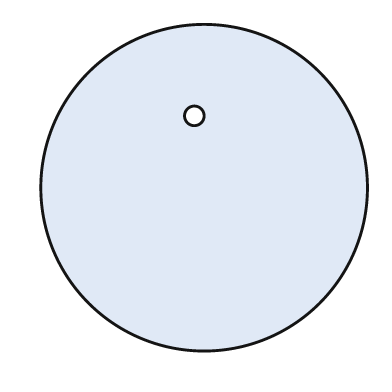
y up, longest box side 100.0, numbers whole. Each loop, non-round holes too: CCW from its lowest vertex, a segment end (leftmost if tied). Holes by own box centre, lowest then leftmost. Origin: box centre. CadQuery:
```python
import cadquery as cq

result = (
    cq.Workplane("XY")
    .moveTo(0.0, 0.0)
    .circle(50.0)
    .moveTo(-3.0, 22.0)
    .circle(3.0)
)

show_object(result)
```